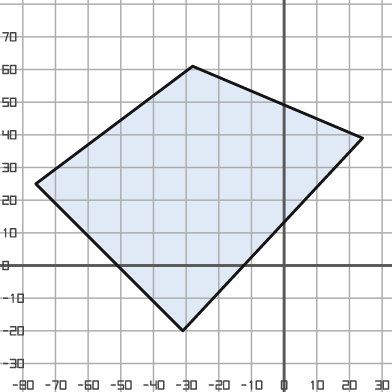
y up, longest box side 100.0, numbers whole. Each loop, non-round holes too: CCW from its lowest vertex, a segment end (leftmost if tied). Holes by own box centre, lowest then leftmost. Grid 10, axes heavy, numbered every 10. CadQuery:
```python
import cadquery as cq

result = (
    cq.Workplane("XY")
    .moveTo(-31.0, -20.0)
    .lineTo(24.0, 39.0)
    .lineTo(-28.0, 61.0)
    .lineTo(-76.0, 25.0)
    .close()
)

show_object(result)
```